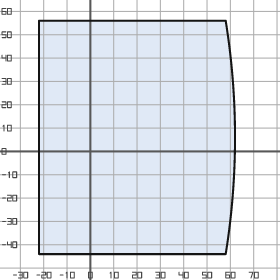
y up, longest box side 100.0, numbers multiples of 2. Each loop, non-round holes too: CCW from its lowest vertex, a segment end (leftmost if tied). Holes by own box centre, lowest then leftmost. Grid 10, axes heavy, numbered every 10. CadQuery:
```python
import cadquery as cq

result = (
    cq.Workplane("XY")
    .moveTo(-22.0, -44.0)
    .lineTo(58.0, -44.0)
    .threePointArc((62.0, 6.0), (58.0, 56.0))
    .lineTo(-22.0, 56.0)
    .close()
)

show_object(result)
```